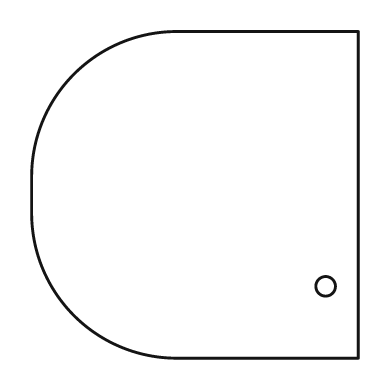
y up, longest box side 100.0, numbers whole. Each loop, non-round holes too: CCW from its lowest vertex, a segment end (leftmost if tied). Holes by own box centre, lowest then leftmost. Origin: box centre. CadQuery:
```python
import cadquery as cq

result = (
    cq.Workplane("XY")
    .moveTo(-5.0, -50.0)
    .lineTo(50.0, -50.0)
    .lineTo(50.0, 50.0)
    .lineTo(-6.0, 50.0)
    .threePointArc((-37.0, 37.0), (-50.0, 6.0))
    .lineTo(-50.0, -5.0)
    .threePointArc((-37.0, -37.0), (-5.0, -50.0))
    .close()
    .moveTo(40.0, -28.0)
    .circle(3.0)
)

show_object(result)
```